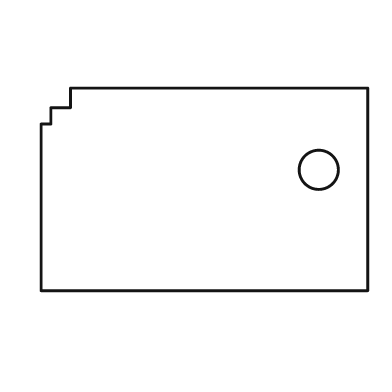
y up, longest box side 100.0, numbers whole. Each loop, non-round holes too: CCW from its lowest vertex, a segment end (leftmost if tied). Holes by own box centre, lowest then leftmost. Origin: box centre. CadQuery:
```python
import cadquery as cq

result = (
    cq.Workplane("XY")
    .moveTo(-50.0, -31.0)
    .lineTo(50.0, -31.0)
    .lineTo(50.0, 31.0)
    .lineTo(-41.0, 31.0)
    .lineTo(-41.0, 25.0)
    .lineTo(-47.0, 25.0)
    .lineTo(-47.0, 20.0)
    .lineTo(-50.0, 20.0)
    .close()
    .moveTo(35.0, 6.0)
    .circle(6.0)
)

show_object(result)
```